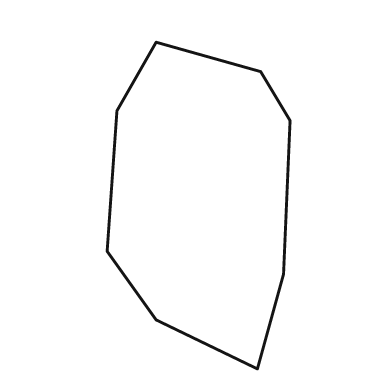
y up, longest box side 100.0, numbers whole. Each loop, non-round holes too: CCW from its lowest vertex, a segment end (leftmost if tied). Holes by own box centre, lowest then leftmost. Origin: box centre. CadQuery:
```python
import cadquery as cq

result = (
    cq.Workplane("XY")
    .moveTo(18.0, -50.0)
    .lineTo(26.0, -21.0)
    .lineTo(28.0, 26.0)
    .lineTo(19.0, 41.0)
    .lineTo(-13.0, 50.0)
    .lineTo(-25.0, 29.0)
    .lineTo(-28.0, -14.0)
    .lineTo(-13.0, -35.0)
    .close()
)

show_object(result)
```